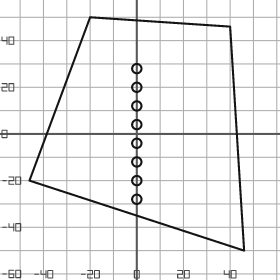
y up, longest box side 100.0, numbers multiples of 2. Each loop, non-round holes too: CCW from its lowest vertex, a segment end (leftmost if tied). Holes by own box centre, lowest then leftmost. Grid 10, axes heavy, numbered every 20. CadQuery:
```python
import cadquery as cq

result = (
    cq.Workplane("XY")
    .moveTo(46.0, -50.0)
    .lineTo(40.0, 46.0)
    .lineTo(-20.0, 50.0)
    .lineTo(-46.0, -20.0)
    .close()
    .moveTo(0.0, -28.0)
    .circle(2.0)
    .moveTo(0.0, -20.0)
    .circle(2.0)
    .moveTo(0.0, -12.0)
    .circle(2.0)
    .moveTo(0.0, -4.0)
    .circle(2.0)
    .moveTo(0.0, 4.0)
    .circle(2.0)
    .moveTo(0.0, 12.0)
    .circle(2.0)
    .moveTo(0.0, 20.0)
    .circle(2.0)
    .moveTo(0.0, 28.0)
    .circle(2.0)
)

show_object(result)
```